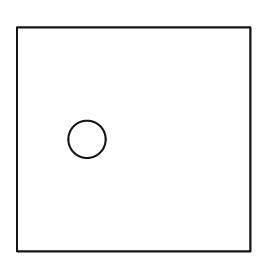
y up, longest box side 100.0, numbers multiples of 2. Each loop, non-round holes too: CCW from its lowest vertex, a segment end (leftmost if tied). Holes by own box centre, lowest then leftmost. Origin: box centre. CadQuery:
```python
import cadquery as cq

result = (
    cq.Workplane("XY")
    .moveTo(-50.0, -48.0)
    .lineTo(50.0, -48.0)
    .lineTo(50.0, 48.0)
    .lineTo(-50.0, 48.0)
    .close()
    .moveTo(-20.0, 0.0)
    .circle(8.0)
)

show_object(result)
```